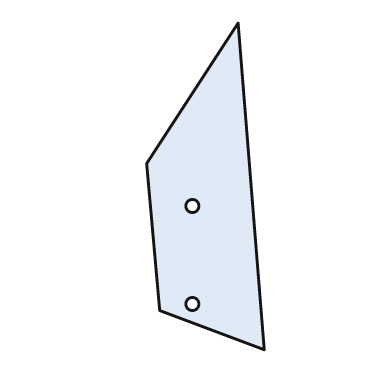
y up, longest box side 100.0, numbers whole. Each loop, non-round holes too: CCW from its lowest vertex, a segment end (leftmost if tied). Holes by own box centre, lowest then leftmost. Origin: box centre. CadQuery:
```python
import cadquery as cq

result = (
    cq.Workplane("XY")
    .moveTo(18.0, -50.0)
    .lineTo(10.0, 50.0)
    .lineTo(-18.0, 7.0)
    .lineTo(-14.0, -38.0)
    .close()
    .moveTo(-4.0, -36.0)
    .circle(2.0)
    .moveTo(-4.0, -6.0)
    .circle(2.0)
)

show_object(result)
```